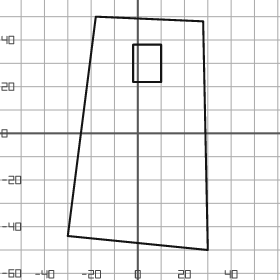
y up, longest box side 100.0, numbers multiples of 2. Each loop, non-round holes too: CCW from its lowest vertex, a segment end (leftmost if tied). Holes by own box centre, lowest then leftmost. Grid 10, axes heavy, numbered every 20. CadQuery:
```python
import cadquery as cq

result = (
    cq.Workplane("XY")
    .moveTo(30.0, -50.0)
    .lineTo(28.0, 48.0)
    .lineTo(-18.0, 50.0)
    .lineTo(-30.0, -44.0)
    .close()
    .moveTo(-2.0, 22.0)
    .lineTo(10.0, 22.0)
    .lineTo(10.0, 38.0)
    .lineTo(-2.0, 38.0)
    .close()
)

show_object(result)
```